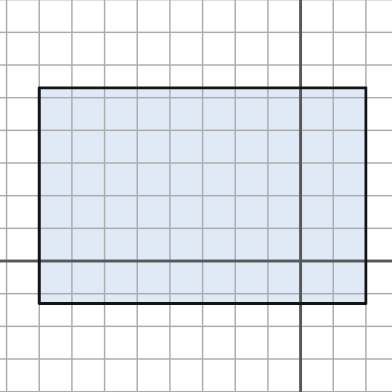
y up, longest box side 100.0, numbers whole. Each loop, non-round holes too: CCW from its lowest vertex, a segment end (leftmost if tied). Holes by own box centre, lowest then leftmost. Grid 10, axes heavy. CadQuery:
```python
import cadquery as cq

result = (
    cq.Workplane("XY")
    .moveTo(-80.0, -13.0)
    .lineTo(20.0, -13.0)
    .lineTo(20.0, 53.0)
    .lineTo(-80.0, 53.0)
    .close()
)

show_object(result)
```